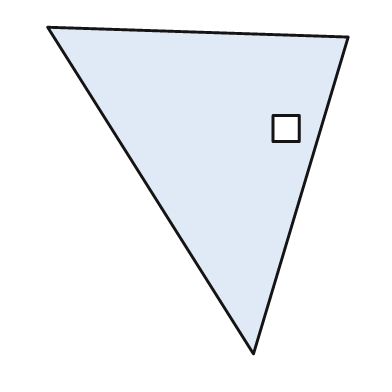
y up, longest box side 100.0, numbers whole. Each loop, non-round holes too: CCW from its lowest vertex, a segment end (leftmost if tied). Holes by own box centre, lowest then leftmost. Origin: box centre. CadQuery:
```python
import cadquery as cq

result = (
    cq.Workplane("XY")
    .moveTo(17.0, -50.0)
    .lineTo(46.0, 47.0)
    .lineTo(-46.0, 50.0)
    .close()
    .moveTo(23.0, 15.0)
    .lineTo(31.0, 15.0)
    .lineTo(31.0, 23.0)
    .lineTo(23.0, 23.0)
    .close()
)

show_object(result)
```